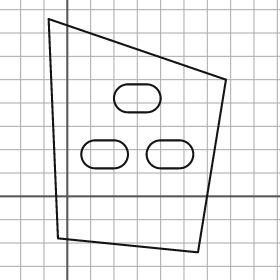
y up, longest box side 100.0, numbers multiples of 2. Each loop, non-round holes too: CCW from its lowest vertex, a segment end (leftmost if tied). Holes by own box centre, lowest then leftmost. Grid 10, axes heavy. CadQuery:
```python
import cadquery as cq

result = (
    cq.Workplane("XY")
    .moveTo(56.0, -24.0)
    .lineTo(68.0, 50.0)
    .lineTo(-8.0, 76.0)
    .lineTo(-4.0, -18.0)
    .close()
    .moveTo(12.0, 12.0)
    .lineTo(20.0, 12.0)
    .threePointArc((26.0, 18.0), (20.0, 24.0))
    .lineTo(12.0, 24.0)
    .threePointArc((6.0, 18.0), (12.0, 12.0))
    .close()
    .moveTo(40.0, 12.0)
    .lineTo(48.0, 12.0)
    .threePointArc((54.0, 18.0), (48.0, 24.0))
    .lineTo(40.0, 24.0)
    .threePointArc((34.0, 18.0), (40.0, 12.0))
    .close()
    .moveTo(26.0, 36.0)
    .lineTo(34.0, 36.0)
    .threePointArc((40.0, 42.0), (34.0, 48.0))
    .lineTo(26.0, 48.0)
    .threePointArc((20.0, 42.0), (26.0, 36.0))
    .close()
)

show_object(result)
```